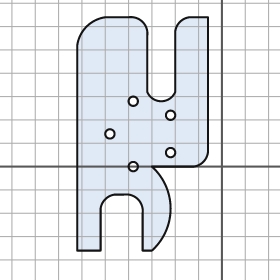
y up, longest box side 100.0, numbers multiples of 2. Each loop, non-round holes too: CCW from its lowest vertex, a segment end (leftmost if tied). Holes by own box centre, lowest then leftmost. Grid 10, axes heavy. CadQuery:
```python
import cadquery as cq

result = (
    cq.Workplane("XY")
    .moveTo(-62.0, -36.0)
    .lineTo(-52.0, -36.0)
    .lineTo(-52.0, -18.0)
    .threePointArc((-50.0, -14.0), (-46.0, -12.0))
    .lineTo(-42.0, -12.0)
    .threePointArc((-36.0, -14.0), (-34.0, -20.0))
    .lineTo(-34.0, -36.0)
    .lineTo(-30.0, -36.0)
    .threePointArc((-22.0, -18.0), (-30.0, 0.0))
    .lineTo(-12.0, 0.0)
    .threePointArc((-8.0, 2.0), (-6.0, 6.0))
    .lineTo(-6.0, 64.0)
    .lineTo(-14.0, 64.0)
    .threePointArc((-18.0, 62.0), (-20.0, 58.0))
    .lineTo(-20.0, 32.0)
    .threePointArc((-26.0, 28.0), (-32.0, 32.0))
    .lineTo(-32.0, 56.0)
    .threePointArc((-34.0, 62.0), (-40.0, 64.0))
    .lineTo(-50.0, 64.0)
    .threePointArc((-58.0, 60.0), (-62.0, 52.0))
    .close()
    .moveTo(-38.0, 0.0)
    .circle(2.0)
    .moveTo(-22.0, 6.0)
    .circle(2.0)
    .moveTo(-48.0, 14.0)
    .circle(2.0)
    .moveTo(-22.0, 22.0)
    .circle(2.0)
    .moveTo(-38.0, 28.0)
    .circle(2.0)
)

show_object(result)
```